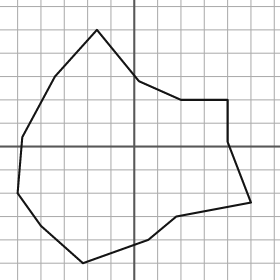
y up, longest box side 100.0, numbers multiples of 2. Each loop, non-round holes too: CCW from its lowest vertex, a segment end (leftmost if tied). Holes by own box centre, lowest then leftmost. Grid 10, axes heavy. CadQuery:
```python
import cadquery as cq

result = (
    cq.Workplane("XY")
    .moveTo(-22.0, -50.0)
    .lineTo(6.0, -40.0)
    .lineTo(18.0, -30.0)
    .lineTo(50.0, -24.0)
    .lineTo(40.0, 2.0)
    .lineTo(40.0, 20.0)
    .lineTo(20.0, 20.0)
    .lineTo(2.0, 28.0)
    .lineTo(-16.0, 50.0)
    .lineTo(-34.0, 30.0)
    .lineTo(-48.0, 4.0)
    .lineTo(-50.0, -20.0)
    .lineTo(-40.0, -34.0)
    .close()
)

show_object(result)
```